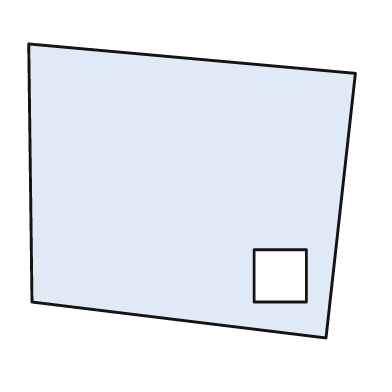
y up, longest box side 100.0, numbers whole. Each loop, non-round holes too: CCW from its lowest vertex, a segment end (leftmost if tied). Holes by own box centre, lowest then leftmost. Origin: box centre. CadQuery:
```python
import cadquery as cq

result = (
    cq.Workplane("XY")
    .moveTo(41.0, -45.0)
    .lineTo(50.0, 36.0)
    .lineTo(-50.0, 45.0)
    .lineTo(-49.0, -34.0)
    .close()
    .moveTo(19.0, -34.0)
    .lineTo(35.0, -34.0)
    .lineTo(35.0, -18.0)
    .lineTo(19.0, -18.0)
    .close()
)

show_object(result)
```